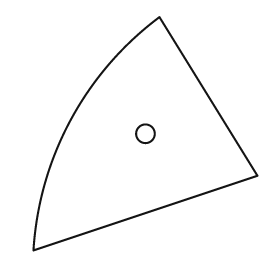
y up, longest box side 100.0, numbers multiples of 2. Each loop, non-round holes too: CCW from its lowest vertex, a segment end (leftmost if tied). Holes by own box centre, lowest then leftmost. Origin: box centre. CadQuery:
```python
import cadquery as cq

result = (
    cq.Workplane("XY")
    .moveTo(-48.0, -50.0)
    .lineTo(48.0, -18.0)
    .lineTo(6.0, 50.0)
    .threePointArc((-32.0, 6.0), (-48.0, -50.0))
    .close()
    .moveTo(0.0, 0.0)
    .circle(4.0)
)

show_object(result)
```